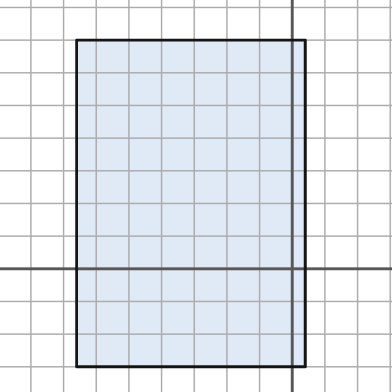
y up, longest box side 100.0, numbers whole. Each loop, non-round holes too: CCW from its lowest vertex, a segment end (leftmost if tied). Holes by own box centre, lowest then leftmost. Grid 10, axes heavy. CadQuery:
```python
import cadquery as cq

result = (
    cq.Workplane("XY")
    .moveTo(-66.0, -30.0)
    .lineTo(4.0, -30.0)
    .lineTo(4.0, 70.0)
    .lineTo(-66.0, 70.0)
    .close()
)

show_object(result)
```